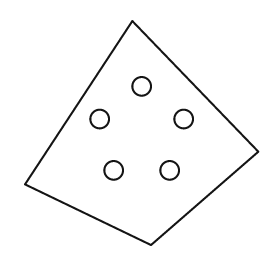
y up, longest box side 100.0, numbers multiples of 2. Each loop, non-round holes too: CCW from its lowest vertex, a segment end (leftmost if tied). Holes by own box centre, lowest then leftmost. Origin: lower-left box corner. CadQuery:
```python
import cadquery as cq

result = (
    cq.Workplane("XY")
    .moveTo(54.0, 0.0)
    .lineTo(100.0, 40.0)
    .lineTo(46.0, 96.0)
    .lineTo(0.0, 26.0)
    .close()
    .moveTo(38.0, 32.0)
    .circle(4.0)
    .moveTo(62.0, 32.0)
    .circle(4.0)
    .moveTo(32.0, 54.0)
    .circle(4.0)
    .moveTo(68.0, 54.0)
    .circle(4.0)
    .moveTo(50.0, 68.0)
    .circle(4.0)
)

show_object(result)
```